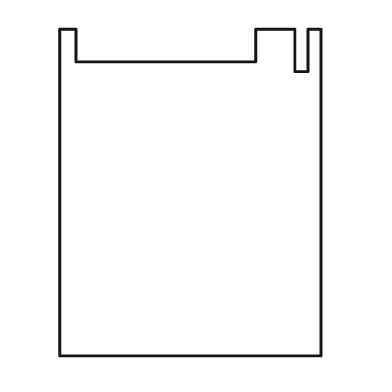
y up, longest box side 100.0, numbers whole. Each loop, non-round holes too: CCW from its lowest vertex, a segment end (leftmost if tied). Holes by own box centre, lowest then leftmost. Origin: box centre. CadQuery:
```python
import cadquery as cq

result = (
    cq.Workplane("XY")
    .moveTo(-40.0, -50.0)
    .lineTo(40.0, -50.0)
    .lineTo(40.0, 50.0)
    .lineTo(36.0, 50.0)
    .lineTo(36.0, 37.0)
    .lineTo(32.0, 37.0)
    .lineTo(32.0, 50.0)
    .lineTo(20.0, 50.0)
    .lineTo(20.0, 40.0)
    .lineTo(-35.0, 40.0)
    .lineTo(-35.0, 50.0)
    .lineTo(-40.0, 50.0)
    .close()
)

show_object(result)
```